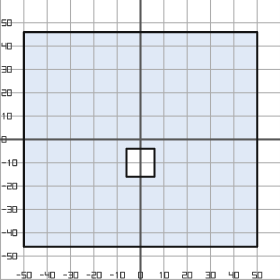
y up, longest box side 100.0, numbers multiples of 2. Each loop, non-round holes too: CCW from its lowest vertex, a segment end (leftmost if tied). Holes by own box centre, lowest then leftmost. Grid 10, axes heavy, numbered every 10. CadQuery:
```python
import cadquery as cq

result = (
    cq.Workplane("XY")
    .moveTo(-50.0, -46.0)
    .lineTo(50.0, -46.0)
    .lineTo(50.0, 46.0)
    .lineTo(-50.0, 46.0)
    .close()
    .moveTo(-6.0, -16.0)
    .lineTo(6.0, -16.0)
    .lineTo(6.0, -4.0)
    .lineTo(-6.0, -4.0)
    .close()
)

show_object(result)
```